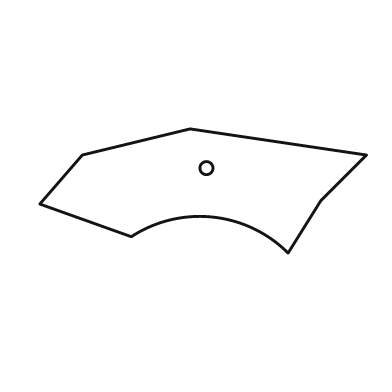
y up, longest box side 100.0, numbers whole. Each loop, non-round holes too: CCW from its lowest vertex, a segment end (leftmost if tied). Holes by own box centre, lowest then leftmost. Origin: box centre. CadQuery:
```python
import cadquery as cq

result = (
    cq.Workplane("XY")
    .moveTo(26.0, -19.0)
    .lineTo(36.0, -3.0)
    .lineTo(50.0, 11.0)
    .lineTo(-4.0, 19.0)
    .lineTo(-37.0, 11.0)
    .lineTo(-50.0, -4.0)
    .lineTo(-22.0, -14.0)
    .threePointArc((3.0, -8.0), (26.0, -19.0))
    .close()
    .moveTo(1.0, 7.0)
    .circle(2.0)
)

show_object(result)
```